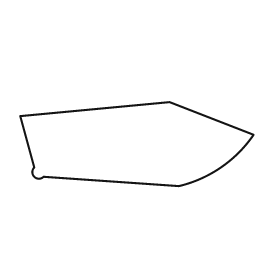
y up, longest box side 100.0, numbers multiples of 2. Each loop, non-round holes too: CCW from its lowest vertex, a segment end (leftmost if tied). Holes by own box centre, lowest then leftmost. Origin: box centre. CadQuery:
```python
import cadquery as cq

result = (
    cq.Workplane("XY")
    .moveTo(18.0, -18.0)
    .threePointArc((36.0, -10.0), (50.0, 4.0))
    .lineTo(14.0, 18.0)
    .lineTo(-50.0, 12.0)
    .lineTo(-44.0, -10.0)
    .threePointArc((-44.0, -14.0), (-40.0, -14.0))
    .close()
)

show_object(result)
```